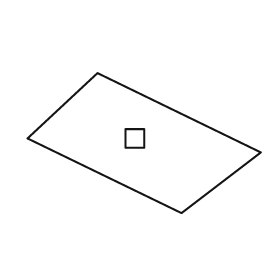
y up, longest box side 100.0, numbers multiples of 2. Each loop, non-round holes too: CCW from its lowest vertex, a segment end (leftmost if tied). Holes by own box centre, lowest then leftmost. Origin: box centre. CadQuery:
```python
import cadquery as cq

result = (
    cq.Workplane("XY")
    .moveTo(16.0, -30.0)
    .lineTo(50.0, -4.0)
    .lineTo(-20.0, 30.0)
    .lineTo(-50.0, 2.0)
    .close()
    .moveTo(-8.0, -2.0)
    .lineTo(0.0, -2.0)
    .lineTo(0.0, 6.0)
    .lineTo(-8.0, 6.0)
    .close()
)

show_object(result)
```